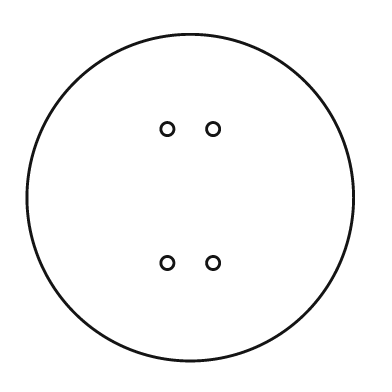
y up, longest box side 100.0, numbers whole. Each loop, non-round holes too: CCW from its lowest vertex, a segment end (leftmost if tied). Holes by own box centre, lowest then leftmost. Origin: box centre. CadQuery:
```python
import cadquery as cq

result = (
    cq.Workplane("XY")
    .moveTo(0.0, 0.0)
    .circle(50.0)
    .moveTo(-7.0, -20.0)
    .circle(2.0)
    .moveTo(7.0, -20.0)
    .circle(2.0)
    .moveTo(-7.0, 21.0)
    .circle(2.0)
    .moveTo(7.0, 21.0)
    .circle(2.0)
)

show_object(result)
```